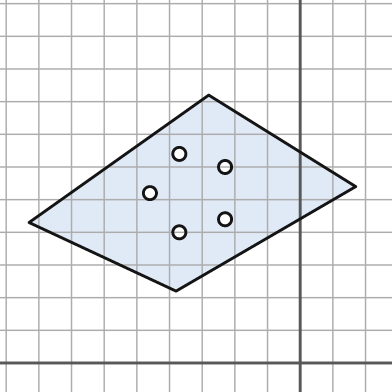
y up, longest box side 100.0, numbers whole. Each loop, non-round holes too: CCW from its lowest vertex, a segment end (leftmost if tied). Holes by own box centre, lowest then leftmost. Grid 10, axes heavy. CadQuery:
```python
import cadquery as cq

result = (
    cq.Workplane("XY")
    .moveTo(-38.0, 22.0)
    .lineTo(17.0, 54.0)
    .lineTo(-28.0, 82.0)
    .lineTo(-83.0, 43.0)
    .close()
    .moveTo(-37.0, 40.0)
    .circle(2.0)
    .moveTo(-23.0, 44.0)
    .circle(2.0)
    .moveTo(-46.0, 52.0)
    .circle(2.0)
    .moveTo(-23.0, 60.0)
    .circle(2.0)
    .moveTo(-37.0, 64.0)
    .circle(2.0)
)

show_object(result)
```